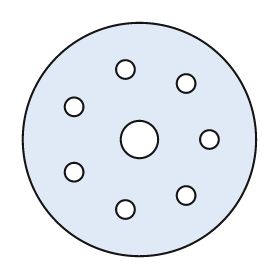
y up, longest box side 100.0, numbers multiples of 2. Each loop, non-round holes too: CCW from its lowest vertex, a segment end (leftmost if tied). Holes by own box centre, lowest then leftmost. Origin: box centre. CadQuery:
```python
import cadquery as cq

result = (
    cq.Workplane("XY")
    .moveTo(0.0, 0.0)
    .circle(50.0)
    .moveTo(-6.0, -30.0)
    .circle(4.0)
    .moveTo(20.0, -24.0)
    .circle(4.0)
    .moveTo(-28.0, -14.0)
    .circle(4.0)
    .moveTo(0.0, 0.0)
    .circle(8.0)
    .moveTo(30.0, 0.0)
    .circle(4.0)
    .moveTo(-28.0, 14.0)
    .circle(4.0)
    .moveTo(20.0, 24.0)
    .circle(4.0)
    .moveTo(-6.0, 30.0)
    .circle(4.0)
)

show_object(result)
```